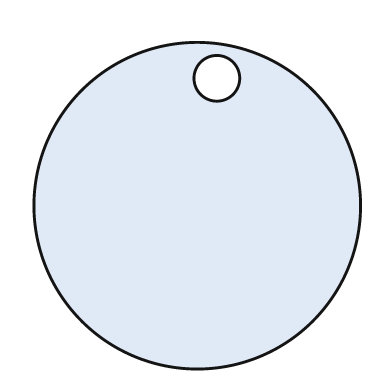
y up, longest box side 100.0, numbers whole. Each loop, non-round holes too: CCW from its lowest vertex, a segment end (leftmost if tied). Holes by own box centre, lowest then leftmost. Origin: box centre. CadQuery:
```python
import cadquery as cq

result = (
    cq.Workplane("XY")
    .moveTo(0.0, 0.0)
    .circle(50.0)
    .moveTo(6.0, 39.0)
    .circle(7.0)
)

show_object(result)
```